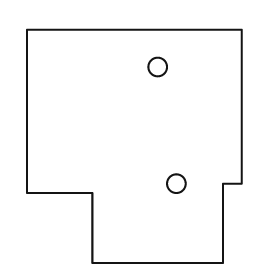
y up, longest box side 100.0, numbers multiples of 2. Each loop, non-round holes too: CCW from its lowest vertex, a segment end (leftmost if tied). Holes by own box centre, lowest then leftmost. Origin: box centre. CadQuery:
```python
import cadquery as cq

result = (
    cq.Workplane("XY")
    .moveTo(-18.0, -50.0)
    .lineTo(38.0, -50.0)
    .lineTo(38.0, -16.0)
    .lineTo(46.0, -16.0)
    .lineTo(46.0, 50.0)
    .lineTo(-46.0, 50.0)
    .lineTo(-46.0, -20.0)
    .lineTo(-18.0, -20.0)
    .close()
    .moveTo(18.0, -16.0)
    .circle(4.0)
    .moveTo(10.0, 34.0)
    .circle(4.0)
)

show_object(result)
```